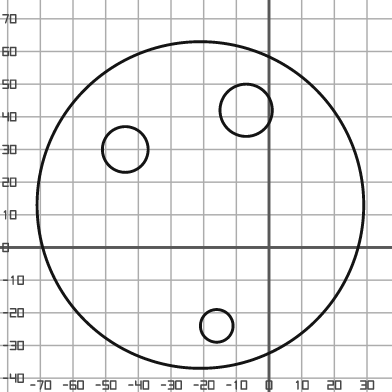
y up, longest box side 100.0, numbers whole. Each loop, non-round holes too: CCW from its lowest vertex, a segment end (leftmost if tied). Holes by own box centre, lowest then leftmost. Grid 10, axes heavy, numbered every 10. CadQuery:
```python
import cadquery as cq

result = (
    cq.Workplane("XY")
    .moveTo(-21.0, 13.0)
    .circle(50.0)
    .moveTo(-16.0, -24.0)
    .circle(5.0)
    .moveTo(-44.0, 30.0)
    .circle(7.0)
    .moveTo(-7.0, 42.0)
    .circle(8.0)
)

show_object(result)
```